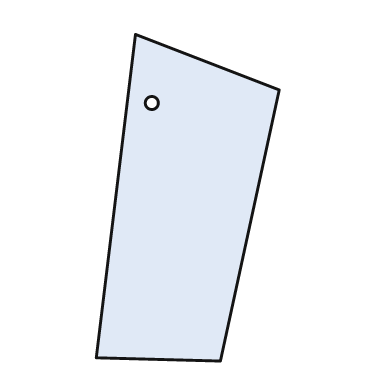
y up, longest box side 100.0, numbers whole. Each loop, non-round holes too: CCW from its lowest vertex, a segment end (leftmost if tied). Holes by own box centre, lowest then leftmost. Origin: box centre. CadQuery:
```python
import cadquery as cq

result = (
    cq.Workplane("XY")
    .moveTo(10.0, -50.0)
    .lineTo(28.0, 33.0)
    .lineTo(-16.0, 50.0)
    .lineTo(-28.0, -49.0)
    .close()
    .moveTo(-11.0, 29.0)
    .circle(2.0)
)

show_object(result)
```